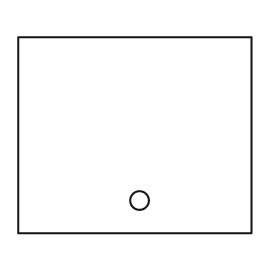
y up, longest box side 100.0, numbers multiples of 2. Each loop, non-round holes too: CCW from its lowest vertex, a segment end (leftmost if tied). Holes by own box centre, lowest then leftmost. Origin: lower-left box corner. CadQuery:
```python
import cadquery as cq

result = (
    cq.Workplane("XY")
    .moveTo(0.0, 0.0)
    .lineTo(100.0, 0.0)
    .lineTo(100.0, 84.0)
    .lineTo(0.0, 84.0)
    .close()
    .moveTo(52.0, 14.0)
    .circle(4.0)
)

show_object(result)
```